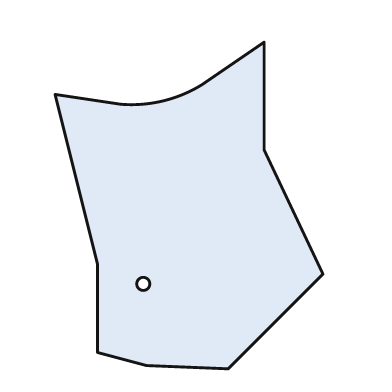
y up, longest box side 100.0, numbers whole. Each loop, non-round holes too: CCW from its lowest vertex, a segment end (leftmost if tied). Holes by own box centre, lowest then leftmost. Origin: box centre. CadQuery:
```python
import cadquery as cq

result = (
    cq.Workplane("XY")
    .moveTo(12.0, -50.0)
    .lineTo(41.0, -21.0)
    .lineTo(23.0, 17.0)
    .lineTo(23.0, 50.0)
    .lineTo(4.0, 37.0)
    .threePointArc((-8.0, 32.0), (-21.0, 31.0))
    .lineTo(-41.0, 34.0)
    .lineTo(-28.0, -18.0)
    .lineTo(-28.0, -45.0)
    .lineTo(-13.0, -49.0)
    .close()
    .moveTo(-14.0, -24.0)
    .circle(2.0)
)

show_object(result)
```